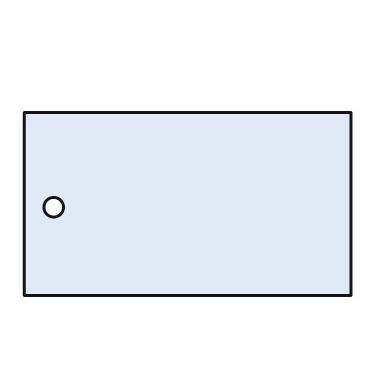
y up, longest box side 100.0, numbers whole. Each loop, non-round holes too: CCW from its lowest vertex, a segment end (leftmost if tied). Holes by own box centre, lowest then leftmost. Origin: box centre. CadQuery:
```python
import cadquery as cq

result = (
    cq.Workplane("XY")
    .moveTo(-50.0, -28.0)
    .lineTo(50.0, -28.0)
    .lineTo(50.0, 28.0)
    .lineTo(-50.0, 28.0)
    .close()
    .moveTo(-41.0, -1.0)
    .circle(3.0)
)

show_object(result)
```